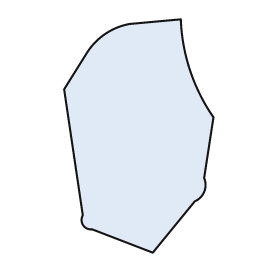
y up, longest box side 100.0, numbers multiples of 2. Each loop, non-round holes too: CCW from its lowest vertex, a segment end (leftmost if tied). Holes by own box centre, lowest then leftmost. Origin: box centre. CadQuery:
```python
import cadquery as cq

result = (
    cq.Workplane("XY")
    .moveTo(6.0, -50.0)
    .lineTo(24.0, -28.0)
    .threePointArc((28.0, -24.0), (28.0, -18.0))
    .lineTo(32.0, 8.0)
    .threePointArc((22.0, 28.0), (18.0, 50.0))
    .lineTo(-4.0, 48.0)
    .threePointArc((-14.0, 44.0), (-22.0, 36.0))
    .lineTo(-32.0, 20.0)
    .lineTo(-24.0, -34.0)
    .threePointArc((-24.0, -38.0), (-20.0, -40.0))
    .close()
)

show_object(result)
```